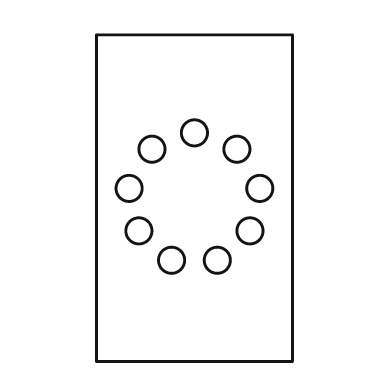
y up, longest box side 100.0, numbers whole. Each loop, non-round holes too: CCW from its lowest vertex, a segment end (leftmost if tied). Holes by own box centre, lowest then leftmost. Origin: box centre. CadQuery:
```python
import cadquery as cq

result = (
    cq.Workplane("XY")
    .moveTo(-30.0, -50.0)
    .lineTo(30.0, -50.0)
    .lineTo(30.0, 50.0)
    .lineTo(-30.0, 50.0)
    .close()
    .moveTo(-7.0, -19.0)
    .circle(4.0)
    .moveTo(7.0, -19.0)
    .circle(4.0)
    .moveTo(-17.0, -10.0)
    .circle(4.0)
    .moveTo(17.0, -10.0)
    .circle(4.0)
    .moveTo(-20.0, 3.0)
    .circle(4.0)
    .moveTo(20.0, 3.0)
    .circle(4.0)
    .moveTo(-13.0, 15.0)
    .circle(4.0)
    .moveTo(13.0, 15.0)
    .circle(4.0)
    .moveTo(0.0, 20.0)
    .circle(4.0)
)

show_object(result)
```